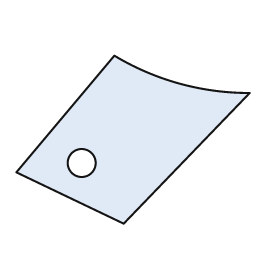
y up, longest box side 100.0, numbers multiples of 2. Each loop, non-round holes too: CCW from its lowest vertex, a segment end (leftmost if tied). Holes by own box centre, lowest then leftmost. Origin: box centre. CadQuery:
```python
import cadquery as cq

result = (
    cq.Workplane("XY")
    .moveTo(-4.0, -36.0)
    .lineTo(50.0, 20.0)
    .threePointArc((20.0, 24.0), (-8.0, 36.0))
    .lineTo(-50.0, -14.0)
    .close()
    .moveTo(-22.0, -10.0)
    .circle(6.0)
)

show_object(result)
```